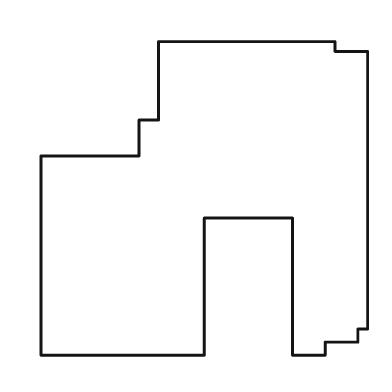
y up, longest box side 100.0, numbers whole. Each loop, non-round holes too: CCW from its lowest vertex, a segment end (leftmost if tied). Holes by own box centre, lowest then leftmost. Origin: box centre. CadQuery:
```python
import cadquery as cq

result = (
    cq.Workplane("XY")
    .moveTo(-50.0, -48.0)
    .lineTo(0.0, -48.0)
    .lineTo(0.0, -6.0)
    .lineTo(27.0, -6.0)
    .lineTo(27.0, -48.0)
    .lineTo(37.0, -48.0)
    .lineTo(37.0, -44.0)
    .lineTo(47.0, -44.0)
    .lineTo(47.0, -40.0)
    .lineTo(50.0, -40.0)
    .lineTo(50.0, 45.0)
    .lineTo(40.0, 45.0)
    .lineTo(40.0, 48.0)
    .lineTo(-14.0, 48.0)
    .lineTo(-14.0, 24.0)
    .lineTo(-20.0, 24.0)
    .lineTo(-20.0, 13.0)
    .lineTo(-50.0, 13.0)
    .close()
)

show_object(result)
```